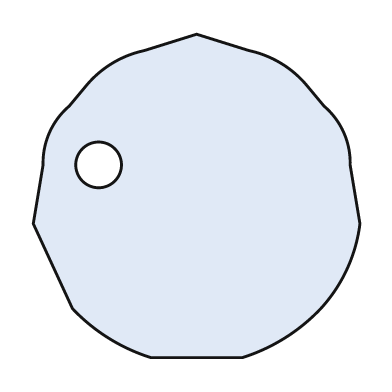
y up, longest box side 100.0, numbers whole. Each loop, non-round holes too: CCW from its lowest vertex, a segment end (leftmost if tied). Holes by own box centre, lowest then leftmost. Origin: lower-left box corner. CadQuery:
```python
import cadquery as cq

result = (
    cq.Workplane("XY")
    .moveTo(36.0, 0.0)
    .lineTo(64.0, 0.0)
    .threePointArc((77.0, 6.0), (88.0, 15.0))
    .threePointArc((96.0, 27.0), (100.0, 41.0))
    .lineTo(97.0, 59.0)
    .threePointArc((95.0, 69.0), (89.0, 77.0))
    .lineTo(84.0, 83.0)
    .threePointArc((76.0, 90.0), (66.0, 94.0))
    .lineTo(50.0, 99.0)
    .lineTo(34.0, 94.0)
    .threePointArc((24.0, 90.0), (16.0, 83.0))
    .lineTo(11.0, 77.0)
    .threePointArc((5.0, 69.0), (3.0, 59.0))
    .lineTo(0.0, 41.0)
    .lineTo(12.0, 15.0)
    .threePointArc((23.0, 6.0), (36.0, 0.0))
    .close()
    .moveTo(20.0, 59.0)
    .circle(7.0)
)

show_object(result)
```